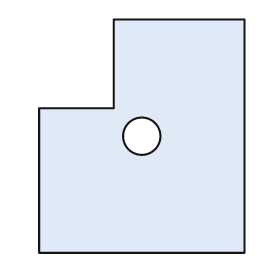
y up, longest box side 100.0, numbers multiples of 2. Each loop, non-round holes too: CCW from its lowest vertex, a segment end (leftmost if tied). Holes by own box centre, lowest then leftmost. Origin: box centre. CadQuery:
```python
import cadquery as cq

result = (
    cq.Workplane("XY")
    .moveTo(-44.0, -50.0)
    .lineTo(44.0, -50.0)
    .lineTo(44.0, 50.0)
    .lineTo(-12.0, 50.0)
    .lineTo(-12.0, 12.0)
    .lineTo(-44.0, 12.0)
    .close()
    .moveTo(0.0, 0.0)
    .circle(8.0)
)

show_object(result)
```